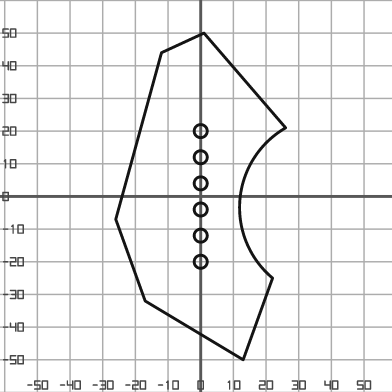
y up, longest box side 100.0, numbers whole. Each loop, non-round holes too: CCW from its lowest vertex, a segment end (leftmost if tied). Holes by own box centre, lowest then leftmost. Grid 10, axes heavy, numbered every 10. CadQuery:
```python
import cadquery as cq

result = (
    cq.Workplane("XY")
    .moveTo(13.0, -50.0)
    .lineTo(22.0, -25.0)
    .threePointArc((12.0, -1.0), (26.0, 21.0))
    .lineTo(1.0, 50.0)
    .lineTo(-12.0, 44.0)
    .lineTo(-26.0, -7.0)
    .lineTo(-17.0, -32.0)
    .close()
    .moveTo(0.0, -20.0)
    .circle(2.0)
    .moveTo(0.0, -12.0)
    .circle(2.0)
    .moveTo(0.0, -4.0)
    .circle(2.0)
    .moveTo(0.0, 4.0)
    .circle(2.0)
    .moveTo(0.0, 12.0)
    .circle(2.0)
    .moveTo(0.0, 20.0)
    .circle(2.0)
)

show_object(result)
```